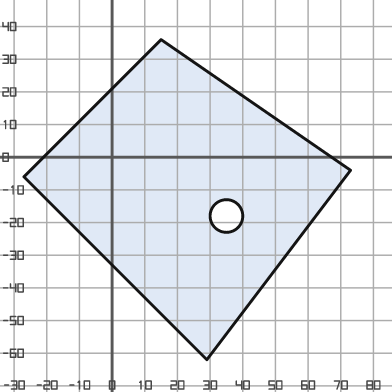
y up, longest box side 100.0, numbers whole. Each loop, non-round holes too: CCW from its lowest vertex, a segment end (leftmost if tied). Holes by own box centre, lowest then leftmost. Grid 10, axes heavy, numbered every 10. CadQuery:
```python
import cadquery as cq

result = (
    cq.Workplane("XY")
    .moveTo(29.0, -62.0)
    .lineTo(73.0, -4.0)
    .lineTo(15.0, 36.0)
    .lineTo(-27.0, -6.0)
    .close()
    .moveTo(35.0, -18.0)
    .circle(5.0)
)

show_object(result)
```